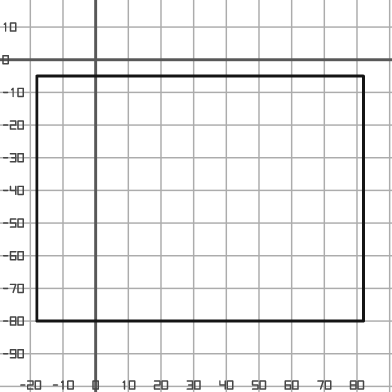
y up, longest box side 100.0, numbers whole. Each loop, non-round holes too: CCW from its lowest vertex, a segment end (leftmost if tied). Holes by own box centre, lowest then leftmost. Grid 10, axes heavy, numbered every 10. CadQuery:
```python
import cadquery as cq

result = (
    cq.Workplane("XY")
    .moveTo(-18.0, -80.0)
    .lineTo(82.0, -80.0)
    .lineTo(82.0, -5.0)
    .lineTo(-18.0, -5.0)
    .close()
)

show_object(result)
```